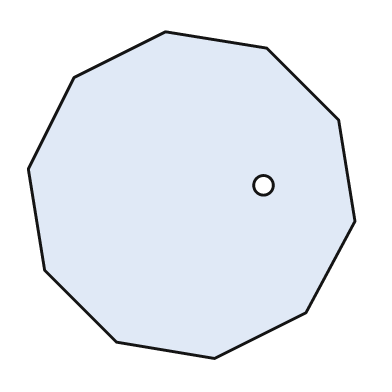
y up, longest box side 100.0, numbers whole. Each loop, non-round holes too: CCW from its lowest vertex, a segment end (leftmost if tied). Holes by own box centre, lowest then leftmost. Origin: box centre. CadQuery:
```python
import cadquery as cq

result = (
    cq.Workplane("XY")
    .moveTo(7.0, -50.0)
    .lineTo(35.0, -36.0)
    .lineTo(50.0, -8.0)
    .lineTo(45.0, 23.0)
    .lineTo(23.0, 45.0)
    .lineTo(-8.0, 50.0)
    .lineTo(-36.0, 36.0)
    .lineTo(-50.0, 8.0)
    .lineTo(-45.0, -23.0)
    .lineTo(-23.0, -45.0)
    .close()
    .moveTo(22.0, 3.0)
    .circle(3.0)
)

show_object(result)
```